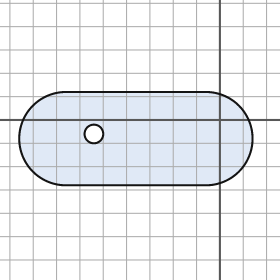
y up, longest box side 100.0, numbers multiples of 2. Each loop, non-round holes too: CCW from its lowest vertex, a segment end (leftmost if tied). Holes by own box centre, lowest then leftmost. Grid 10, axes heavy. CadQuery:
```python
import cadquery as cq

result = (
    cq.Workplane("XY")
    .moveTo(-66.0, -28.0)
    .lineTo(-6.0, -28.0)
    .threePointArc((14.0, -8.0), (-6.0, 12.0))
    .lineTo(-66.0, 12.0)
    .threePointArc((-86.0, -8.0), (-66.0, -28.0))
    .close()
    .moveTo(-54.0, -6.0)
    .circle(4.0)
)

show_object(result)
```